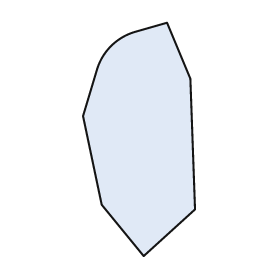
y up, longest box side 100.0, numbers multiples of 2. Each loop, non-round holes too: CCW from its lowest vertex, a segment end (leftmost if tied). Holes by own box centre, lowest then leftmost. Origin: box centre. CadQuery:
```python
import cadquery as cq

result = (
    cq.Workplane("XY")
    .moveTo(2.0, -50.0)
    .lineTo(24.0, -30.0)
    .lineTo(22.0, 26.0)
    .lineTo(12.0, 50.0)
    .lineTo(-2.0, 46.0)
    .threePointArc((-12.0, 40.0), (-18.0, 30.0))
    .lineTo(-24.0, 10.0)
    .lineTo(-16.0, -28.0)
    .close()
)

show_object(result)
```